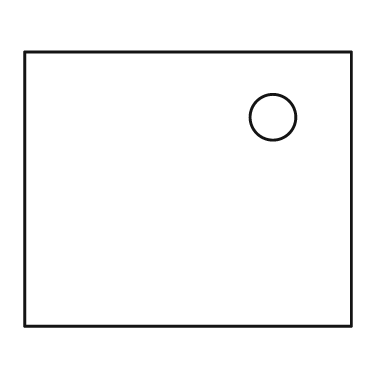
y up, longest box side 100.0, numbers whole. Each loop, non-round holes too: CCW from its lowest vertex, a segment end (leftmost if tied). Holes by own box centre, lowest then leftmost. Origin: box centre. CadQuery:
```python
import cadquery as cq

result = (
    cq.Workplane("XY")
    .moveTo(-50.0, -42.0)
    .lineTo(50.0, -42.0)
    .lineTo(50.0, 42.0)
    .lineTo(-50.0, 42.0)
    .close()
    .moveTo(26.0, 22.0)
    .circle(7.0)
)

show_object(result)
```